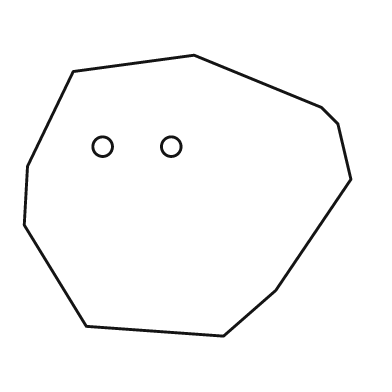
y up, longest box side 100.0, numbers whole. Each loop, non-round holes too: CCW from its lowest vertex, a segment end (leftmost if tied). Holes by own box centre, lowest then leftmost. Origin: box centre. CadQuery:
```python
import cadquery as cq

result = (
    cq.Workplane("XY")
    .moveTo(11.0, -43.0)
    .lineTo(27.0, -29.0)
    .lineTo(50.0, 5.0)
    .lineTo(46.0, 22.0)
    .lineTo(41.0, 27.0)
    .lineTo(2.0, 43.0)
    .lineTo(-35.0, 38.0)
    .lineTo(-49.0, 9.0)
    .lineTo(-50.0, -9.0)
    .lineTo(-31.0, -40.0)
    .close()
    .moveTo(-26.0, 15.0)
    .circle(3.0)
    .moveTo(-5.0, 15.0)
    .circle(3.0)
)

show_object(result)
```